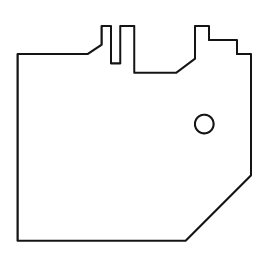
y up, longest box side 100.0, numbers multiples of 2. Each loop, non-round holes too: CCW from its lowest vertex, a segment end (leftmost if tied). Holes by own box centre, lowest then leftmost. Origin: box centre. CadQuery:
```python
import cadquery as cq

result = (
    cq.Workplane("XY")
    .moveTo(-50.0, -46.0)
    .lineTo(22.0, -46.0)
    .lineTo(50.0, -18.0)
    .lineTo(50.0, 34.0)
    .lineTo(44.0, 34.0)
    .lineTo(44.0, 40.0)
    .lineTo(32.0, 40.0)
    .lineTo(32.0, 46.0)
    .lineTo(26.0, 46.0)
    .lineTo(26.0, 32.0)
    .lineTo(18.0, 26.0)
    .lineTo(0.0, 26.0)
    .lineTo(0.0, 46.0)
    .lineTo(-6.0, 46.0)
    .lineTo(-6.0, 30.0)
    .lineTo(-10.0, 30.0)
    .lineTo(-10.0, 46.0)
    .lineTo(-14.0, 46.0)
    .lineTo(-14.0, 38.0)
    .lineTo(-20.0, 34.0)
    .lineTo(-50.0, 34.0)
    .close()
    .moveTo(30.0, 4.0)
    .circle(4.0)
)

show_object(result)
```